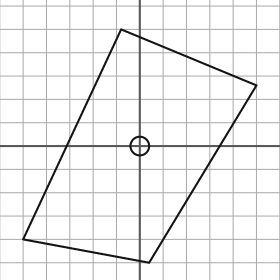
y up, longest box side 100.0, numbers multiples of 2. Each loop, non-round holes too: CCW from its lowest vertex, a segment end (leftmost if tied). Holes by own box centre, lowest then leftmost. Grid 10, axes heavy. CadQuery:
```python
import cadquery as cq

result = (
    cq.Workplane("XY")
    .moveTo(4.0, -50.0)
    .lineTo(50.0, 26.0)
    .lineTo(-8.0, 50.0)
    .lineTo(-50.0, -40.0)
    .close()
    .moveTo(0.0, 0.0)
    .circle(4.0)
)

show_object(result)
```